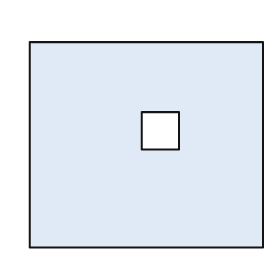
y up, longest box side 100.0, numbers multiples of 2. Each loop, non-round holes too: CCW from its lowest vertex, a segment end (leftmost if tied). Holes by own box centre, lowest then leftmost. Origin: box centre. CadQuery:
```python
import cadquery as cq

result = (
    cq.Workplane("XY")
    .moveTo(-50.0, -44.0)
    .lineTo(50.0, -44.0)
    .lineTo(50.0, 44.0)
    .lineTo(-50.0, 44.0)
    .close()
    .moveTo(-2.0, -2.0)
    .lineTo(14.0, -2.0)
    .lineTo(14.0, 14.0)
    .lineTo(-2.0, 14.0)
    .close()
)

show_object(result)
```